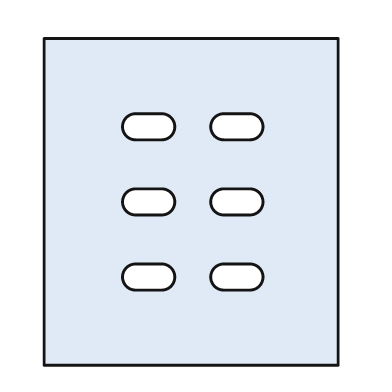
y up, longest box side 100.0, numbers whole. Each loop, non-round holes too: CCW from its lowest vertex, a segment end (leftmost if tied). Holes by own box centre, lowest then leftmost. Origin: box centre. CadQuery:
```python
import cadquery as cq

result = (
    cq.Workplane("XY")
    .moveTo(-45.0, -50.0)
    .lineTo(45.0, -50.0)
    .lineTo(45.0, 50.0)
    .lineTo(-45.0, 50.0)
    .close()
    .moveTo(-17.0, -27.0)
    .lineTo(-9.0, -27.0)
    .threePointArc((-5.0, -23.0), (-9.0, -19.0))
    .lineTo(-17.0, -19.0)
    .threePointArc((-21.0, -23.0), (-17.0, -27.0))
    .close()
    .moveTo(10.0, -27.0)
    .lineTo(18.0, -27.0)
    .threePointArc((22.0, -23.0), (18.0, -19.0))
    .lineTo(10.0, -19.0)
    .threePointArc((6.0, -23.0), (10.0, -27.0))
    .close()
    .moveTo(-17.0, -4.0)
    .lineTo(-9.0, -4.0)
    .threePointArc((-5.0, 0.0), (-9.0, 4.0))
    .lineTo(-17.0, 4.0)
    .threePointArc((-21.0, 0.0), (-17.0, -4.0))
    .close()
    .moveTo(10.0, -4.0)
    .lineTo(18.0, -4.0)
    .threePointArc((22.0, 0.0), (18.0, 4.0))
    .lineTo(10.0, 4.0)
    .threePointArc((6.0, 0.0), (10.0, -4.0))
    .close()
    .moveTo(-17.0, 19.0)
    .lineTo(-9.0, 19.0)
    .threePointArc((-5.0, 23.0), (-9.0, 27.0))
    .lineTo(-17.0, 27.0)
    .threePointArc((-21.0, 23.0), (-17.0, 19.0))
    .close()
    .moveTo(10.0, 19.0)
    .lineTo(18.0, 19.0)
    .threePointArc((22.0, 23.0), (18.0, 27.0))
    .lineTo(10.0, 27.0)
    .threePointArc((6.0, 23.0), (10.0, 19.0))
    .close()
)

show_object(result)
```